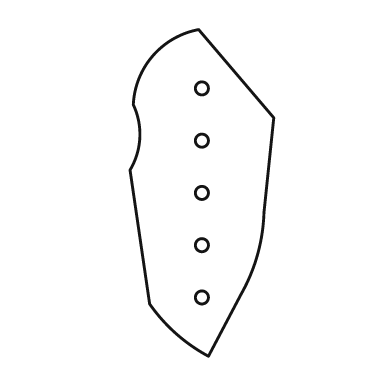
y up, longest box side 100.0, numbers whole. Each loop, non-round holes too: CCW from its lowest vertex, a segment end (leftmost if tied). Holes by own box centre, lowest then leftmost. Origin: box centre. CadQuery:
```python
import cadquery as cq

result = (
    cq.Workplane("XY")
    .moveTo(2.0, -50.0)
    .lineTo(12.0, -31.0)
    .threePointArc((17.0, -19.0), (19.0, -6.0))
    .lineTo(22.0, 23.0)
    .lineTo(-1.0, 50.0)
    .threePointArc((-15.0, 42.0), (-21.0, 27.0))
    .threePointArc((-19.0, 17.0), (-22.0, 7.0))
    .lineTo(-16.0, -34.0)
    .threePointArc((-8.0, -43.0), (2.0, -50.0))
    .close()
    .moveTo(0.0, -32.0)
    .circle(2.0)
    .moveTo(0.0, -16.0)
    .circle(2.0)
    .moveTo(0.0, 0.0)
    .circle(2.0)
    .moveTo(0.0, 16.0)
    .circle(2.0)
    .moveTo(0.0, 32.0)
    .circle(2.0)
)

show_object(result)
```